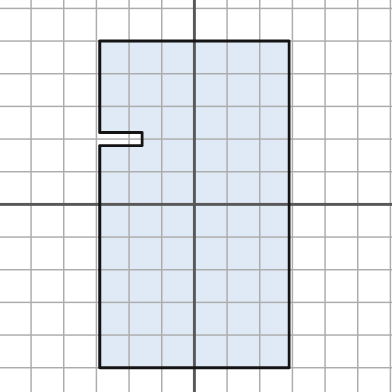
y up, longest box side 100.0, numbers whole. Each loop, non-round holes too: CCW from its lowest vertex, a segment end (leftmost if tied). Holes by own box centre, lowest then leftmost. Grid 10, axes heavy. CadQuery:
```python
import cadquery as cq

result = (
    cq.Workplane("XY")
    .moveTo(-29.0, -50.0)
    .lineTo(29.0, -50.0)
    .lineTo(29.0, 50.0)
    .lineTo(-29.0, 50.0)
    .lineTo(-29.0, 22.0)
    .lineTo(-16.0, 22.0)
    .lineTo(-16.0, 18.0)
    .lineTo(-29.0, 18.0)
    .close()
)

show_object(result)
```